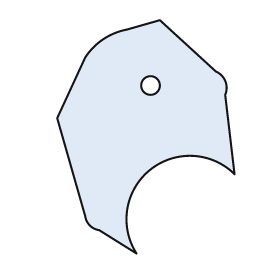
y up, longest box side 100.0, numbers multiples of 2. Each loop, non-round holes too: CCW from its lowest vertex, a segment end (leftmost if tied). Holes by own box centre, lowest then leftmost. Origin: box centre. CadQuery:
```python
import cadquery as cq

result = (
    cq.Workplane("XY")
    .moveTo(-4.0, -50.0)
    .threePointArc((2.0, -14.0), (38.0, -16.0))
    .lineTo(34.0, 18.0)
    .threePointArc((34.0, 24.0), (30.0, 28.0))
    .lineTo(6.0, 50.0)
    .lineTo(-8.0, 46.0)
    .threePointArc((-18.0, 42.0), (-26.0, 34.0))
    .lineTo(-38.0, 8.0)
    .lineTo(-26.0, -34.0)
    .threePointArc((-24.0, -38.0), (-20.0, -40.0))
    .close()
    .moveTo(2.0, 22.0)
    .circle(4.0)
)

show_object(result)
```